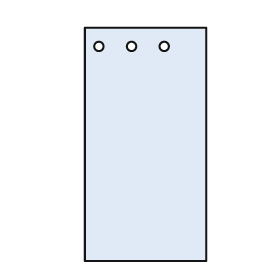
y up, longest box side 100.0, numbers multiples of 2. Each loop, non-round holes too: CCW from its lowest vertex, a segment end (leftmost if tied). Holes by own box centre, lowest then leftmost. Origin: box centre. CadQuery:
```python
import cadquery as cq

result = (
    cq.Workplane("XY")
    .moveTo(-26.0, -50.0)
    .lineTo(26.0, -50.0)
    .lineTo(26.0, 50.0)
    .lineTo(-26.0, 50.0)
    .close()
    .moveTo(-20.0, 42.0)
    .circle(2.0)
    .moveTo(-6.0, 42.0)
    .circle(2.0)
    .moveTo(8.0, 42.0)
    .circle(2.0)
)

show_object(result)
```